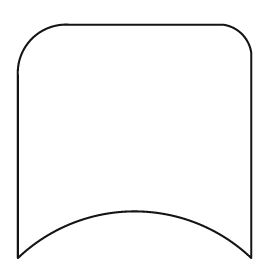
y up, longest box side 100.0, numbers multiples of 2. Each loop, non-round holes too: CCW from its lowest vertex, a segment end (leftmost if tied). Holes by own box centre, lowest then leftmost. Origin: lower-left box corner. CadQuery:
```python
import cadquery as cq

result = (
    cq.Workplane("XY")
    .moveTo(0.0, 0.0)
    .threePointArc((50.0, 20.0), (100.0, 0.0))
    .lineTo(100.0, 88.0)
    .threePointArc((96.0, 96.0), (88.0, 100.0))
    .lineTo(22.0, 100.0)
    .threePointArc((6.0, 94.0), (0.0, 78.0))
    .close()
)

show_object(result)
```